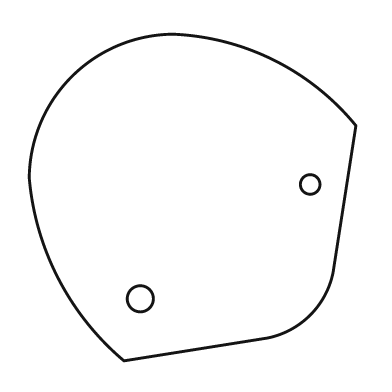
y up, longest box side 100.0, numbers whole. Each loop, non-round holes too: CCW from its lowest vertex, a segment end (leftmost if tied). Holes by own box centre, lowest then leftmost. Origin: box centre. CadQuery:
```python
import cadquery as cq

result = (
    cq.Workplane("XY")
    .moveTo(-21.0, -50.0)
    .lineTo(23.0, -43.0)
    .threePointArc((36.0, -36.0), (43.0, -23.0))
    .lineTo(50.0, 22.0)
    .threePointArc((25.0, 42.0), (-6.0, 50.0))
    .threePointArc((-37.0, 37.0), (-50.0, 6.0))
    .threePointArc((-41.0, -25.0), (-21.0, -50.0))
    .close()
    .moveTo(-16.0, -31.0)
    .circle(4.0)
    .moveTo(36.0, 4.0)
    .circle(3.0)
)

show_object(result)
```